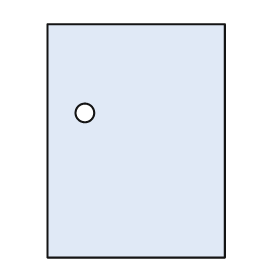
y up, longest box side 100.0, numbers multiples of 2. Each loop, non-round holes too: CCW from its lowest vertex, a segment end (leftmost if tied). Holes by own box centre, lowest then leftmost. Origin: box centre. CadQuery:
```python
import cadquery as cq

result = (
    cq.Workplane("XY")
    .moveTo(-38.0, -50.0)
    .lineTo(38.0, -50.0)
    .lineTo(38.0, 50.0)
    .lineTo(-38.0, 50.0)
    .close()
    .moveTo(-22.0, 12.0)
    .circle(4.0)
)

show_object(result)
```